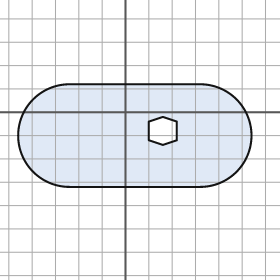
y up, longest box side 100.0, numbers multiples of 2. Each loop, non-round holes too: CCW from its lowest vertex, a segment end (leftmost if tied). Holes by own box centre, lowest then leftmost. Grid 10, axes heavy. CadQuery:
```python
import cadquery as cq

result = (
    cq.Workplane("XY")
    .moveTo(-24.0, -32.0)
    .lineTo(32.0, -32.0)
    .threePointArc((54.0, -10.0), (32.0, 12.0))
    .lineTo(-24.0, 12.0)
    .threePointArc((-46.0, -10.0), (-24.0, -32.0))
    .close()
    .moveTo(16.0, -14.0)
    .lineTo(22.0, -12.0)
    .lineTo(22.0, -4.0)
    .lineTo(16.0, -2.0)
    .lineTo(10.0, -4.0)
    .lineTo(10.0, -12.0)
    .close()
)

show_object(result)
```